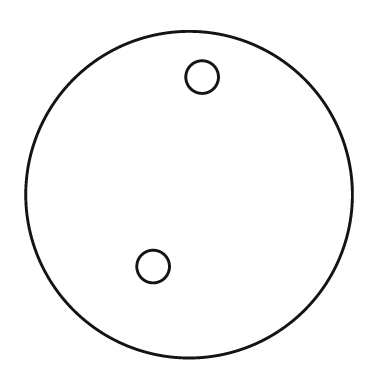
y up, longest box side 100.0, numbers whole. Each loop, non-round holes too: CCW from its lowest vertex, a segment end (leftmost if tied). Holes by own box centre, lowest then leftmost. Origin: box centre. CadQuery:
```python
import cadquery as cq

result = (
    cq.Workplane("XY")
    .moveTo(0.0, 0.0)
    .circle(50.0)
    .moveTo(-11.0, -22.0)
    .circle(5.0)
    .moveTo(4.0, 36.0)
    .circle(5.0)
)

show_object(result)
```